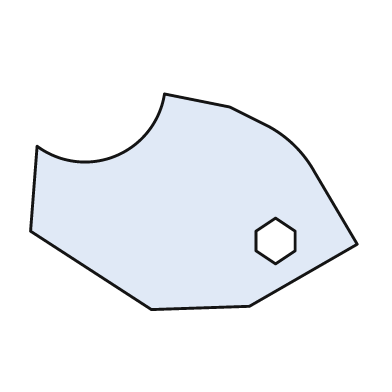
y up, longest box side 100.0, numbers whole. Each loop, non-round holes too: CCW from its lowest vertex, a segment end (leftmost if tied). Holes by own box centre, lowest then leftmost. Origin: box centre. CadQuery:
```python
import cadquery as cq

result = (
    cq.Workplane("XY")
    .moveTo(-13.0, -33.0)
    .lineTo(17.0, -32.0)
    .lineTo(50.0, -13.0)
    .lineTo(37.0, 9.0)
    .threePointArc((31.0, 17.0), (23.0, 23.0))
    .lineTo(11.0, 29.0)
    .lineTo(-9.0, 33.0)
    .threePointArc((-24.0, 14.0), (-48.0, 17.0))
    .lineTo(-50.0, -9.0)
    .close()
    .moveTo(25.0, -19.0)
    .lineTo(31.0, -15.0)
    .lineTo(31.0, -9.0)
    .lineTo(25.0, -5.0)
    .lineTo(19.0, -9.0)
    .lineTo(19.0, -15.0)
    .close()
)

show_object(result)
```